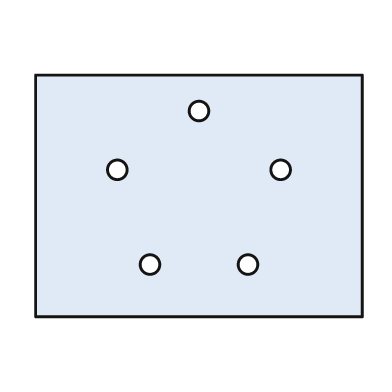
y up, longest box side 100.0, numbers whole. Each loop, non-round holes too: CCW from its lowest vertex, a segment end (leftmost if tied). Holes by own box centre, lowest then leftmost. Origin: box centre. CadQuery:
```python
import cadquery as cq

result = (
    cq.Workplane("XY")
    .moveTo(-50.0, -37.0)
    .lineTo(50.0, -37.0)
    .lineTo(50.0, 37.0)
    .lineTo(-50.0, 37.0)
    .close()
    .moveTo(-15.0, -21.0)
    .circle(3.0)
    .moveTo(15.0, -21.0)
    .circle(3.0)
    .moveTo(-25.0, 8.0)
    .circle(3.0)
    .moveTo(25.0, 8.0)
    .circle(3.0)
    .moveTo(0.0, 26.0)
    .circle(3.0)
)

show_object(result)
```